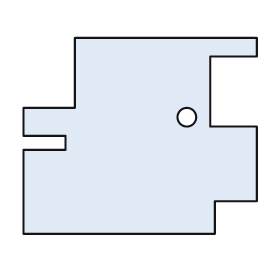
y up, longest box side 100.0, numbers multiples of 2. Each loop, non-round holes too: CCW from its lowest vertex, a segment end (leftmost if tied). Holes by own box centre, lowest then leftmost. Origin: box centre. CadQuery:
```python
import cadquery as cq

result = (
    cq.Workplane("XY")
    .moveTo(-50.0, -42.0)
    .lineTo(32.0, -42.0)
    .lineTo(32.0, -28.0)
    .lineTo(50.0, -28.0)
    .lineTo(50.0, 4.0)
    .lineTo(30.0, 4.0)
    .lineTo(30.0, 34.0)
    .lineTo(50.0, 34.0)
    .lineTo(50.0, 42.0)
    .lineTo(-28.0, 42.0)
    .lineTo(-28.0, 12.0)
    .lineTo(-50.0, 12.0)
    .lineTo(-50.0, 0.0)
    .lineTo(-32.0, 0.0)
    .lineTo(-32.0, -6.0)
    .lineTo(-50.0, -6.0)
    .close()
    .moveTo(20.0, 8.0)
    .circle(4.0)
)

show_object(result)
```